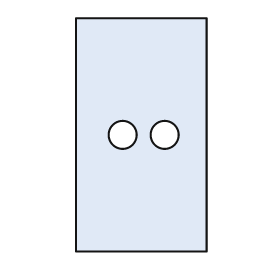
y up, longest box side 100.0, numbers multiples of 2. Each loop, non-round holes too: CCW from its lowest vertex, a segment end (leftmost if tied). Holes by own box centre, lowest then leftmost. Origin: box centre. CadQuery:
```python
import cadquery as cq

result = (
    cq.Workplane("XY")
    .moveTo(-28.0, -50.0)
    .lineTo(28.0, -50.0)
    .lineTo(28.0, 50.0)
    .lineTo(-28.0, 50.0)
    .close()
    .moveTo(-8.0, 0.0)
    .circle(6.0)
    .moveTo(10.0, 0.0)
    .circle(6.0)
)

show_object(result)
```